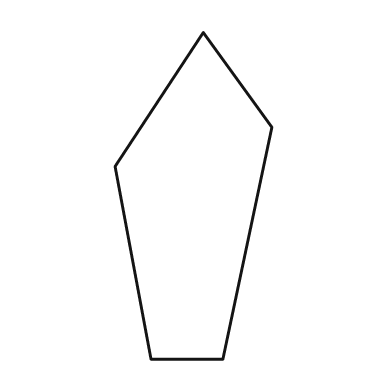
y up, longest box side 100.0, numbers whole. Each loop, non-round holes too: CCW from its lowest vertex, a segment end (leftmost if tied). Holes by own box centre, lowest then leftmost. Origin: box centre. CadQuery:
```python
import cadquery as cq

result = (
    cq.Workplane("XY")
    .moveTo(-13.0, -50.0)
    .lineTo(9.0, -50.0)
    .lineTo(24.0, 21.0)
    .lineTo(3.0, 50.0)
    .lineTo(-24.0, 9.0)
    .close()
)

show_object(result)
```